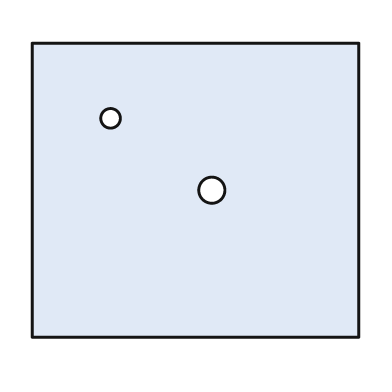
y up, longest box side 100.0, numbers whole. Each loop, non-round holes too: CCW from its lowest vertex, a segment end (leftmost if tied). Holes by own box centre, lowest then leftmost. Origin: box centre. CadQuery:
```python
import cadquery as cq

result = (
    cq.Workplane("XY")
    .moveTo(-50.0, -45.0)
    .lineTo(50.0, -45.0)
    .lineTo(50.0, 45.0)
    .lineTo(-50.0, 45.0)
    .close()
    .moveTo(5.0, 0.0)
    .circle(4.0)
    .moveTo(-26.0, 22.0)
    .circle(3.0)
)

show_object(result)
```